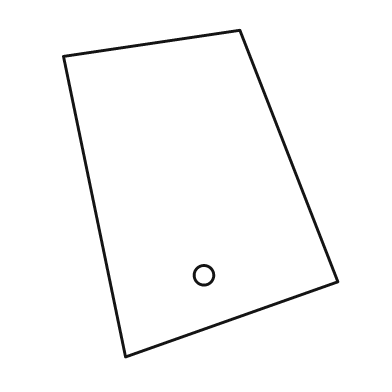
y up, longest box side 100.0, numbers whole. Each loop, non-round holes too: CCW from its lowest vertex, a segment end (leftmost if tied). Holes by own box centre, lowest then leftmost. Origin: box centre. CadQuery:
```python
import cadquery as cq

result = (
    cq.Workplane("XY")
    .moveTo(-23.0, -50.0)
    .lineTo(42.0, -27.0)
    .lineTo(12.0, 50.0)
    .lineTo(-42.0, 42.0)
    .close()
    .moveTo(1.0, -25.0)
    .circle(3.0)
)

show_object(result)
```